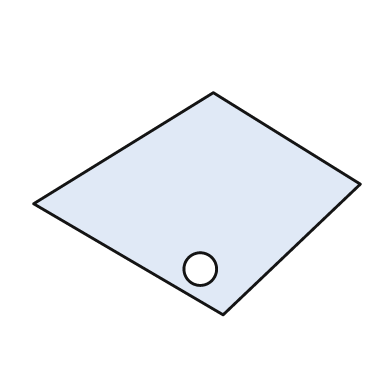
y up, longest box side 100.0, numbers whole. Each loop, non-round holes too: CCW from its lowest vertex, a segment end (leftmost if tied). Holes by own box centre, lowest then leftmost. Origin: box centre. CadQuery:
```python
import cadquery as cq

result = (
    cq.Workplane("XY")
    .moveTo(8.0, -34.0)
    .lineTo(50.0, 6.0)
    .lineTo(5.0, 34.0)
    .lineTo(-50.0, 0.0)
    .close()
    .moveTo(1.0, -20.0)
    .circle(5.0)
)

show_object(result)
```